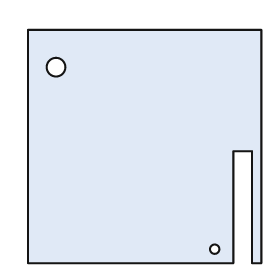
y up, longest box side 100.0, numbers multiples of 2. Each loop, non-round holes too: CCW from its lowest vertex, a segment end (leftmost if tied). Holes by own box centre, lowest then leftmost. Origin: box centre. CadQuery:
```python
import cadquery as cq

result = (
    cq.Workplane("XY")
    .moveTo(-50.0, -50.0)
    .lineTo(38.0, -50.0)
    .lineTo(38.0, -2.0)
    .lineTo(46.0, -2.0)
    .lineTo(46.0, -50.0)
    .lineTo(50.0, -50.0)
    .lineTo(50.0, 50.0)
    .lineTo(-50.0, 50.0)
    .close()
    .moveTo(30.0, -44.0)
    .circle(2.0)
    .moveTo(-38.0, 34.0)
    .circle(4.0)
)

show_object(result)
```